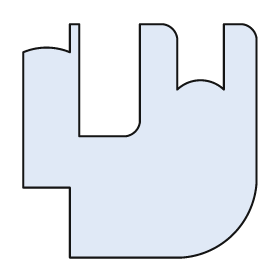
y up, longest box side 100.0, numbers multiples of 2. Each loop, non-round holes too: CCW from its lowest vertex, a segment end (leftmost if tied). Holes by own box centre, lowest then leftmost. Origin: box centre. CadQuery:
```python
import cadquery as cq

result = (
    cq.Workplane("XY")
    .moveTo(-30.0, -50.0)
    .lineTo(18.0, -50.0)
    .threePointArc((40.0, -40.0), (50.0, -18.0))
    .lineTo(50.0, 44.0)
    .threePointArc((48.0, 48.0), (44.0, 50.0))
    .lineTo(36.0, 50.0)
    .lineTo(36.0, 22.0)
    .threePointArc((26.0, 26.0), (16.0, 22.0))
    .lineTo(16.0, 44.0)
    .threePointArc((14.0, 48.0), (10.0, 50.0))
    .lineTo(0.0, 50.0)
    .lineTo(0.0, 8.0)
    .threePointArc((-2.0, 4.0), (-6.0, 2.0))
    .lineTo(-26.0, 2.0)
    .lineTo(-26.0, 50.0)
    .lineTo(-30.0, 50.0)
    .lineTo(-30.0, 38.0)
    .threePointArc((-40.0, 40.0), (-50.0, 38.0))
    .lineTo(-50.0, -20.0)
    .lineTo(-30.0, -20.0)
    .close()
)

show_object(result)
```